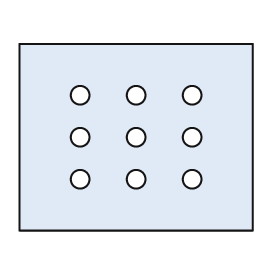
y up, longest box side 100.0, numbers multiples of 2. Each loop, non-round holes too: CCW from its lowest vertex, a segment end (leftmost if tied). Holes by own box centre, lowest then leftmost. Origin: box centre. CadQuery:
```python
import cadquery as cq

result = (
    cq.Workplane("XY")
    .moveTo(-50.0, -40.0)
    .lineTo(50.0, -40.0)
    .lineTo(50.0, 40.0)
    .lineTo(-50.0, 40.0)
    .close()
    .moveTo(-24.0, -18.0)
    .circle(4.0)
    .moveTo(0.0, -18.0)
    .circle(4.0)
    .moveTo(24.0, -18.0)
    .circle(4.0)
    .moveTo(-24.0, 0.0)
    .circle(4.0)
    .moveTo(0.0, 0.0)
    .circle(4.0)
    .moveTo(24.0, 0.0)
    .circle(4.0)
    .moveTo(-24.0, 18.0)
    .circle(4.0)
    .moveTo(0.0, 18.0)
    .circle(4.0)
    .moveTo(24.0, 18.0)
    .circle(4.0)
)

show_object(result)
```